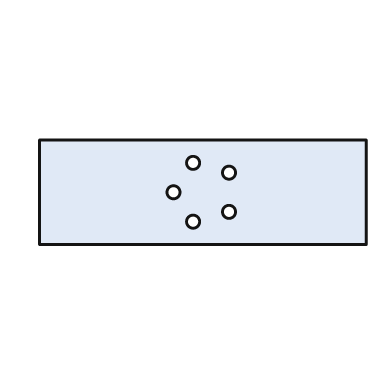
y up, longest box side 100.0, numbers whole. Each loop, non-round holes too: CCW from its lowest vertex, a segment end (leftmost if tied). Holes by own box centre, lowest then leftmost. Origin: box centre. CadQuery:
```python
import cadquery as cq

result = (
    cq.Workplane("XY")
    .moveTo(-50.0, -16.0)
    .lineTo(50.0, -16.0)
    .lineTo(50.0, 16.0)
    .lineTo(-50.0, 16.0)
    .close()
    .moveTo(-3.0, -9.0)
    .circle(2.0)
    .moveTo(8.0, -6.0)
    .circle(2.0)
    .moveTo(-9.0, 0.0)
    .circle(2.0)
    .moveTo(8.0, 6.0)
    .circle(2.0)
    .moveTo(-3.0, 9.0)
    .circle(2.0)
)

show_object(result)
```